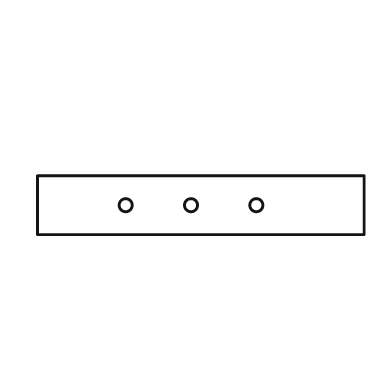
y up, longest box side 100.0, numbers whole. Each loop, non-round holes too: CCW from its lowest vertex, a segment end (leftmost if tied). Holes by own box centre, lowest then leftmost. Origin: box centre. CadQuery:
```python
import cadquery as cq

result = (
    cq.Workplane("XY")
    .moveTo(-50.0, -9.0)
    .lineTo(50.0, -9.0)
    .lineTo(50.0, 9.0)
    .lineTo(-50.0, 9.0)
    .close()
    .moveTo(-23.0, 0.0)
    .circle(2.0)
    .moveTo(-3.0, 0.0)
    .circle(2.0)
    .moveTo(17.0, 0.0)
    .circle(2.0)
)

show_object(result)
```